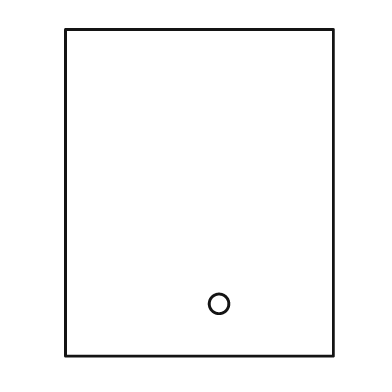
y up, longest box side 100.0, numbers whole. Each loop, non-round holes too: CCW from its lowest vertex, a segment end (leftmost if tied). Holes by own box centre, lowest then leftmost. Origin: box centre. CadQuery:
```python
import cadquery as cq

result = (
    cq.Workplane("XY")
    .moveTo(-41.0, -50.0)
    .lineTo(41.0, -50.0)
    .lineTo(41.0, 50.0)
    .lineTo(-41.0, 50.0)
    .close()
    .moveTo(6.0, -34.0)
    .circle(3.0)
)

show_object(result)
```